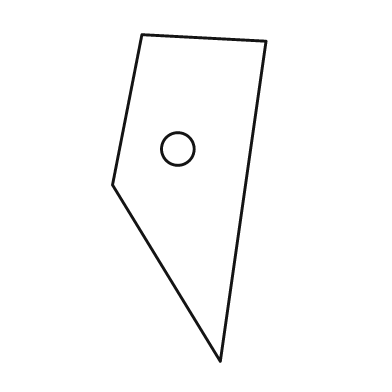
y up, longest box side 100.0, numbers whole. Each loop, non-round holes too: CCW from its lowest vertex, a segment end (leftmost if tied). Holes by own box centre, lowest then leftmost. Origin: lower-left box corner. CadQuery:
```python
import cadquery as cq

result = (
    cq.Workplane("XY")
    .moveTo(33.0, 0.0)
    .lineTo(47.0, 98.0)
    .lineTo(9.0, 100.0)
    .lineTo(0.0, 54.0)
    .close()
    .moveTo(20.0, 65.0)
    .circle(5.0)
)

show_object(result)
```